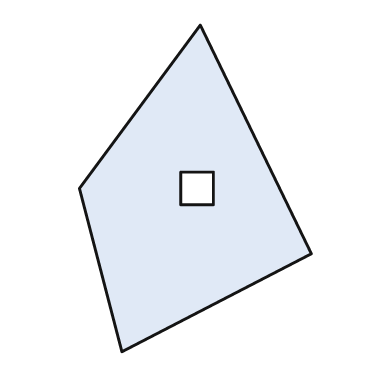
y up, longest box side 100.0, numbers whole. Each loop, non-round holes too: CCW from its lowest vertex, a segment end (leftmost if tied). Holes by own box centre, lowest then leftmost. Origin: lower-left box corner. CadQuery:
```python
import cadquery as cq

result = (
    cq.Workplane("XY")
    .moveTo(13.0, 0.0)
    .lineTo(71.0, 30.0)
    .lineTo(37.0, 100.0)
    .lineTo(0.0, 50.0)
    .close()
    .moveTo(31.0, 45.0)
    .lineTo(41.0, 45.0)
    .lineTo(41.0, 55.0)
    .lineTo(31.0, 55.0)
    .close()
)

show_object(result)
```